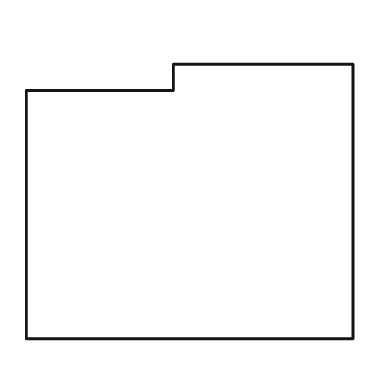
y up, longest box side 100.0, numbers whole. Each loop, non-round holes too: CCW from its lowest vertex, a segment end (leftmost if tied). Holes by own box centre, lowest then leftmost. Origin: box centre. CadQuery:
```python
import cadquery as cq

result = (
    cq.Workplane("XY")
    .moveTo(-50.0, -42.0)
    .lineTo(50.0, -42.0)
    .lineTo(50.0, 42.0)
    .lineTo(-5.0, 42.0)
    .lineTo(-5.0, 34.0)
    .lineTo(-50.0, 34.0)
    .close()
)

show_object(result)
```